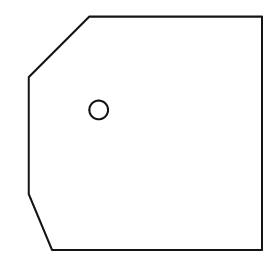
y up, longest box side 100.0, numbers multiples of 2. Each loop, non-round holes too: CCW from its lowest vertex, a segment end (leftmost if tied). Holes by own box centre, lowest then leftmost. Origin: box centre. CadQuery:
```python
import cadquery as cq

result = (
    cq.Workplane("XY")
    .moveTo(-40.0, -50.0)
    .lineTo(50.0, -50.0)
    .lineTo(50.0, 50.0)
    .lineTo(-24.0, 50.0)
    .lineTo(-50.0, 24.0)
    .lineTo(-50.0, -26.0)
    .close()
    .moveTo(-20.0, 10.0)
    .circle(4.0)
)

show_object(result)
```